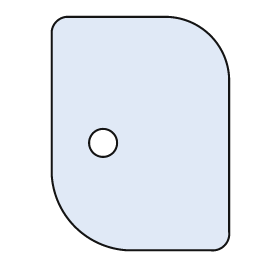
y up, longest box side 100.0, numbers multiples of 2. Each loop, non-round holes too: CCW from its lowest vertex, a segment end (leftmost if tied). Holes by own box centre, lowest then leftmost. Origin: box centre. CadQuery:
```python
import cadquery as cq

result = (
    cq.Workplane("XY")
    .moveTo(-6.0, -50.0)
    .lineTo(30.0, -50.0)
    .threePointArc((36.0, -48.0), (38.0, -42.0))
    .lineTo(38.0, 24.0)
    .threePointArc((30.0, 42.0), (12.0, 50.0))
    .lineTo(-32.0, 50.0)
    .threePointArc((-36.0, 48.0), (-38.0, 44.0))
    .lineTo(-38.0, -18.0)
    .threePointArc((-28.0, -40.0), (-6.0, -50.0))
    .close()
    .moveTo(-16.0, -4.0)
    .circle(6.0)
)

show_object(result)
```